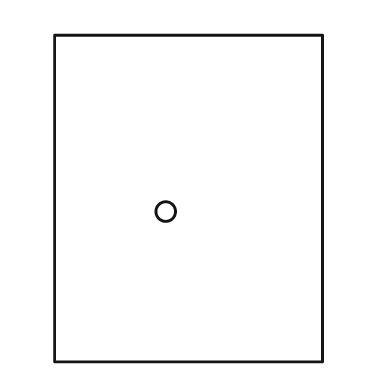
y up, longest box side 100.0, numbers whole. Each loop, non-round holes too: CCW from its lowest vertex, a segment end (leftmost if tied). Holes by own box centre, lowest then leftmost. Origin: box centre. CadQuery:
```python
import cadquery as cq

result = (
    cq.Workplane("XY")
    .moveTo(-41.0, -50.0)
    .lineTo(41.0, -50.0)
    .lineTo(41.0, 50.0)
    .lineTo(-41.0, 50.0)
    .close()
    .moveTo(-7.0, -4.0)
    .circle(3.0)
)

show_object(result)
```